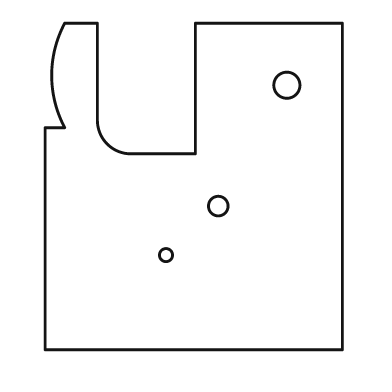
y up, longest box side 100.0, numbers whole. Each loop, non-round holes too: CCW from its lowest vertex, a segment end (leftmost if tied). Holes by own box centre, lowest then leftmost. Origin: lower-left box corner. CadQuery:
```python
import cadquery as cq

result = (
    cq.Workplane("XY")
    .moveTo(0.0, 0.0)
    .lineTo(91.0, 0.0)
    .lineTo(91.0, 100.0)
    .lineTo(46.0, 100.0)
    .lineTo(46.0, 60.0)
    .lineTo(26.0, 60.0)
    .threePointArc((19.0, 63.0), (16.0, 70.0))
    .lineTo(16.0, 100.0)
    .lineTo(6.0, 100.0)
    .threePointArc((2.0, 84.0), (6.0, 68.0))
    .lineTo(0.0, 68.0)
    .close()
    .moveTo(37.0, 29.0)
    .circle(2.0)
    .moveTo(53.0, 44.0)
    .circle(3.0)
    .moveTo(74.0, 81.0)
    .circle(4.0)
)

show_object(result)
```